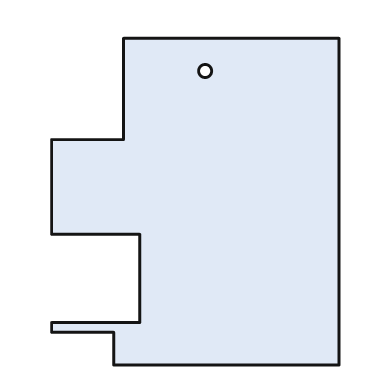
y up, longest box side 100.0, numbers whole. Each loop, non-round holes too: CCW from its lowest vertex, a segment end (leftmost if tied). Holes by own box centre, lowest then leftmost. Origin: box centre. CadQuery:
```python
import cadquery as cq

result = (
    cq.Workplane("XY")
    .moveTo(-25.0, -50.0)
    .lineTo(44.0, -50.0)
    .lineTo(44.0, 50.0)
    .lineTo(-22.0, 50.0)
    .lineTo(-22.0, 19.0)
    .lineTo(-44.0, 19.0)
    .lineTo(-44.0, -10.0)
    .lineTo(-17.0, -10.0)
    .lineTo(-17.0, -37.0)
    .lineTo(-44.0, -37.0)
    .lineTo(-44.0, -40.0)
    .lineTo(-25.0, -40.0)
    .close()
    .moveTo(3.0, 40.0)
    .circle(2.0)
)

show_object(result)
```